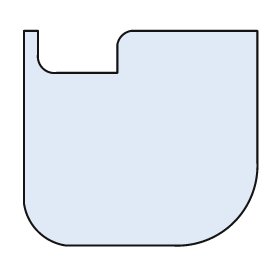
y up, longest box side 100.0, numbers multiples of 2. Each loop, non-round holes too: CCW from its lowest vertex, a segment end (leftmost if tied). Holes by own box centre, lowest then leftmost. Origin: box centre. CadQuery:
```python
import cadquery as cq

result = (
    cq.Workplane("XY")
    .moveTo(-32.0, -46.0)
    .lineTo(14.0, -46.0)
    .threePointArc((40.0, -36.0), (50.0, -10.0))
    .lineTo(50.0, 46.0)
    .lineTo(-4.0, 46.0)
    .threePointArc((-8.0, 44.0), (-10.0, 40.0))
    .lineTo(-10.0, 28.0)
    .lineTo(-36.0, 28.0)
    .threePointArc((-42.0, 30.0), (-44.0, 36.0))
    .lineTo(-44.0, 46.0)
    .lineTo(-50.0, 46.0)
    .lineTo(-50.0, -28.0)
    .threePointArc((-44.0, -40.0), (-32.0, -46.0))
    .close()
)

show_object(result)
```